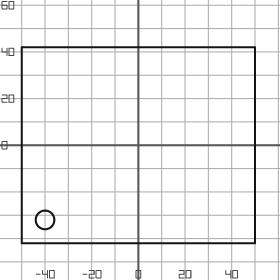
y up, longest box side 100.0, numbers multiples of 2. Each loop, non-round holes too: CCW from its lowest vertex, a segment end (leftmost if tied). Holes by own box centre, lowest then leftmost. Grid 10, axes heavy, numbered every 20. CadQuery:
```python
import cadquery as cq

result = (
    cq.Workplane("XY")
    .moveTo(-50.0, -42.0)
    .lineTo(50.0, -42.0)
    .lineTo(50.0, 42.0)
    .lineTo(-50.0, 42.0)
    .close()
    .moveTo(-40.0, -32.0)
    .circle(4.0)
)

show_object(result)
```